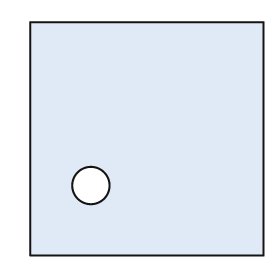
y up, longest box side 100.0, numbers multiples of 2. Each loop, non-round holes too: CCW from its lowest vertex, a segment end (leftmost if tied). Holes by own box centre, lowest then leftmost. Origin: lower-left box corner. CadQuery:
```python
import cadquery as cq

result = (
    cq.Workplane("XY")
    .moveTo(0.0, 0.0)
    .lineTo(100.0, 0.0)
    .lineTo(100.0, 100.0)
    .lineTo(0.0, 100.0)
    .close()
    .moveTo(26.0, 30.0)
    .circle(8.0)
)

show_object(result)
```